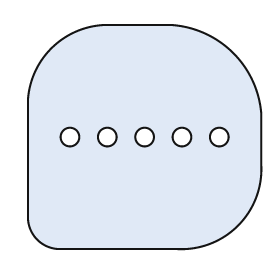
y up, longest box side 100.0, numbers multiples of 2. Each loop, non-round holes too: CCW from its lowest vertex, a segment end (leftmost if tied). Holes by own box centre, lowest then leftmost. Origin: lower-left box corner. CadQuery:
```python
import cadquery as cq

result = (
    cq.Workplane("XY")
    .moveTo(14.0, 0.0)
    .lineTo(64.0, 0.0)
    .threePointArc((90.0, 10.0), (100.0, 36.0))
    .lineTo(100.0, 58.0)
    .threePointArc((88.0, 84.0), (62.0, 96.0))
    .lineTo(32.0, 96.0)
    .threePointArc((10.0, 86.0), (0.0, 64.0))
    .lineTo(0.0, 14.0)
    .threePointArc((4.0, 4.0), (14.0, 0.0))
    .close()
    .moveTo(18.0, 48.0)
    .circle(4.0)
    .moveTo(34.0, 48.0)
    .circle(4.0)
    .moveTo(50.0, 48.0)
    .circle(4.0)
    .moveTo(66.0, 48.0)
    .circle(4.0)
    .moveTo(82.0, 48.0)
    .circle(4.0)
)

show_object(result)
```